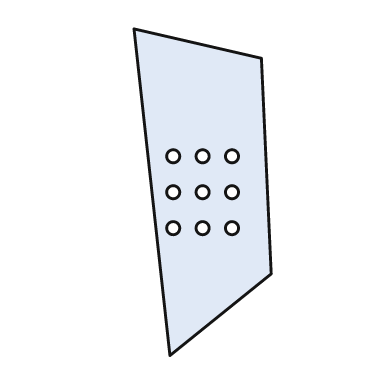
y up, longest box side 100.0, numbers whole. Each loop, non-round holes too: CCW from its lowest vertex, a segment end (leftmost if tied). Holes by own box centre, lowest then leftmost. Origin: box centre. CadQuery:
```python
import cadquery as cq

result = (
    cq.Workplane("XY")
    .moveTo(-10.0, -50.0)
    .lineTo(21.0, -25.0)
    .lineTo(18.0, 41.0)
    .lineTo(-21.0, 50.0)
    .close()
    .moveTo(-9.0, -11.0)
    .circle(2.0)
    .moveTo(0.0, -11.0)
    .circle(2.0)
    .moveTo(9.0, -11.0)
    .circle(2.0)
    .moveTo(-9.0, 0.0)
    .circle(2.0)
    .moveTo(0.0, 0.0)
    .circle(2.0)
    .moveTo(9.0, 0.0)
    .circle(2.0)
    .moveTo(-9.0, 11.0)
    .circle(2.0)
    .moveTo(0.0, 11.0)
    .circle(2.0)
    .moveTo(9.0, 11.0)
    .circle(2.0)
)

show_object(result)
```